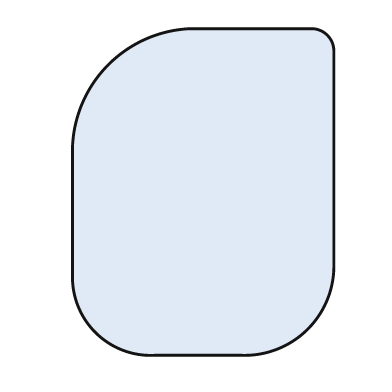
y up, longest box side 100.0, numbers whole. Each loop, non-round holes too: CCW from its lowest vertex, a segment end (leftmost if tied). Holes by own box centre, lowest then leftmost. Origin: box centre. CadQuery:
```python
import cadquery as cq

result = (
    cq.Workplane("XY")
    .moveTo(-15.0, -50.0)
    .lineTo(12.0, -50.0)
    .threePointArc((32.0, -42.0), (40.0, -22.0))
    .lineTo(40.0, 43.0)
    .threePointArc((38.0, 48.0), (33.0, 50.0))
    .lineTo(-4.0, 50.0)
    .threePointArc((-29.0, 39.0), (-40.0, 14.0))
    .lineTo(-40.0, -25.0)
    .threePointArc((-33.0, -43.0), (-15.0, -50.0))
    .close()
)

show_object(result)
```